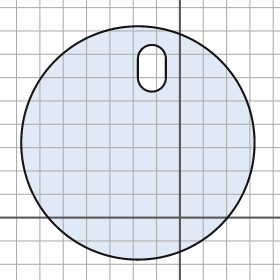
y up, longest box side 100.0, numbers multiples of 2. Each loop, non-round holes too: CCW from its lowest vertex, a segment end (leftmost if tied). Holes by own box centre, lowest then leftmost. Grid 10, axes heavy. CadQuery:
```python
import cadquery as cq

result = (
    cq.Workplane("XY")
    .moveTo(-18.0, 32.0)
    .circle(50.0)
    .moveTo(-18.0, 60.0)
    .threePointArc((-12.0, 54.0), (-6.0, 60.0))
    .lineTo(-6.0, 68.0)
    .threePointArc((-12.0, 74.0), (-18.0, 68.0))
    .close()
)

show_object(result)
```